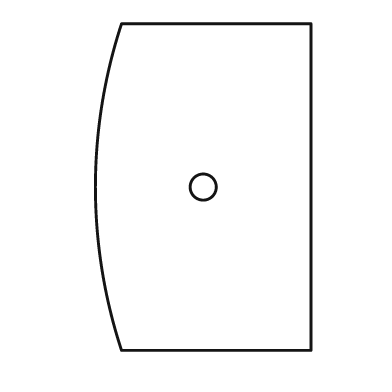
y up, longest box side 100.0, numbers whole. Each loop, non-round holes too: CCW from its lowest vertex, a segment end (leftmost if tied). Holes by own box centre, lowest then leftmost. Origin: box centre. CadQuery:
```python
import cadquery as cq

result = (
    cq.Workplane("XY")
    .moveTo(-25.0, -50.0)
    .lineTo(33.0, -50.0)
    .lineTo(33.0, 50.0)
    .lineTo(-25.0, 50.0)
    .threePointArc((-33.0, 0.0), (-25.0, -50.0))
    .close()
    .moveTo(0.0, 0.0)
    .circle(4.0)
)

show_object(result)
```